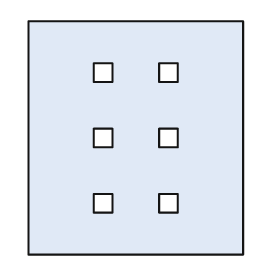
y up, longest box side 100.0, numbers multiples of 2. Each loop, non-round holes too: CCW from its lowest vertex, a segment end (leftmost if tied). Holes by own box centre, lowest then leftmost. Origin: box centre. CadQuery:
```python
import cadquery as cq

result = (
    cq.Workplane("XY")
    .moveTo(-46.0, -50.0)
    .lineTo(46.0, -50.0)
    .lineTo(46.0, 50.0)
    .lineTo(-46.0, 50.0)
    .close()
    .moveTo(-18.0, -32.0)
    .lineTo(-10.0, -32.0)
    .lineTo(-10.0, -24.0)
    .lineTo(-18.0, -24.0)
    .close()
    .moveTo(10.0, -32.0)
    .lineTo(18.0, -32.0)
    .lineTo(18.0, -24.0)
    .lineTo(10.0, -24.0)
    .close()
    .moveTo(-18.0, -4.0)
    .lineTo(-10.0, -4.0)
    .lineTo(-10.0, 4.0)
    .lineTo(-18.0, 4.0)
    .close()
    .moveTo(10.0, -4.0)
    .lineTo(18.0, -4.0)
    .lineTo(18.0, 4.0)
    .lineTo(10.0, 4.0)
    .close()
    .moveTo(-18.0, 24.0)
    .lineTo(-10.0, 24.0)
    .lineTo(-10.0, 32.0)
    .lineTo(-18.0, 32.0)
    .close()
    .moveTo(10.0, 24.0)
    .lineTo(18.0, 24.0)
    .lineTo(18.0, 32.0)
    .lineTo(10.0, 32.0)
    .close()
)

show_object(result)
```